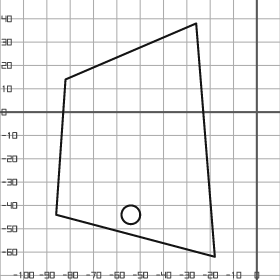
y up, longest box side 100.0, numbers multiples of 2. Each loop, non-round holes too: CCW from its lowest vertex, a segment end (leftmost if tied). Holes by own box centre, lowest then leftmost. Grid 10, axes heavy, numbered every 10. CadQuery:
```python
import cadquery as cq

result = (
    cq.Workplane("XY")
    .moveTo(-18.0, -62.0)
    .lineTo(-26.0, 38.0)
    .lineTo(-82.0, 14.0)
    .lineTo(-86.0, -44.0)
    .close()
    .moveTo(-54.0, -44.0)
    .circle(4.0)
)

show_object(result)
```